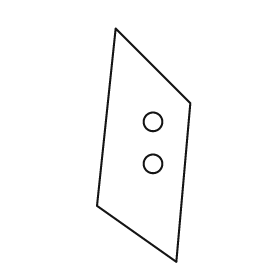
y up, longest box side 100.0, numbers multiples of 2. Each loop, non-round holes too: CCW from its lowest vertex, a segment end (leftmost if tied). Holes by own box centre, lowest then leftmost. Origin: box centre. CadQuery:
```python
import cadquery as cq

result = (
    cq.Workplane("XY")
    .moveTo(14.0, -50.0)
    .lineTo(20.0, 18.0)
    .lineTo(-12.0, 50.0)
    .lineTo(-20.0, -26.0)
    .close()
    .moveTo(4.0, -8.0)
    .circle(4.0)
    .moveTo(4.0, 10.0)
    .circle(4.0)
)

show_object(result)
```